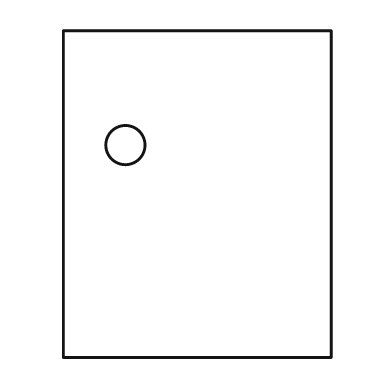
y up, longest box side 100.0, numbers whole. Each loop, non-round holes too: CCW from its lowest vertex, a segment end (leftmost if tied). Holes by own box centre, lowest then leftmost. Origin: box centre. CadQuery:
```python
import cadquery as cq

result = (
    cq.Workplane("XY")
    .moveTo(-41.0, -50.0)
    .lineTo(41.0, -50.0)
    .lineTo(41.0, 50.0)
    .lineTo(-41.0, 50.0)
    .close()
    .moveTo(-22.0, 15.0)
    .circle(6.0)
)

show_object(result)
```